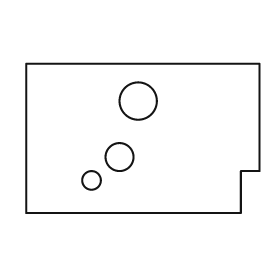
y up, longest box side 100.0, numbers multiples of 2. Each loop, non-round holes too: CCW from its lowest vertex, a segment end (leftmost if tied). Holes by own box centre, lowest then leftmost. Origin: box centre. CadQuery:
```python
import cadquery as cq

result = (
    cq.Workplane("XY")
    .moveTo(-50.0, -32.0)
    .lineTo(42.0, -32.0)
    .lineTo(42.0, -14.0)
    .lineTo(50.0, -14.0)
    .lineTo(50.0, 32.0)
    .lineTo(-50.0, 32.0)
    .close()
    .moveTo(-22.0, -18.0)
    .circle(4.0)
    .moveTo(-10.0, -8.0)
    .circle(6.0)
    .moveTo(-2.0, 16.0)
    .circle(8.0)
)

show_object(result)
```